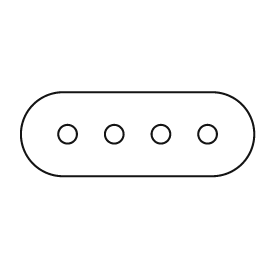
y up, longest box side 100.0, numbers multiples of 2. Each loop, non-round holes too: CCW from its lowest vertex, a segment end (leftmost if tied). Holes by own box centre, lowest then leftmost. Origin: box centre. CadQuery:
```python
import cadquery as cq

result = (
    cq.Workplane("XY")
    .moveTo(-32.0, -18.0)
    .lineTo(32.0, -18.0)
    .threePointArc((50.0, 0.0), (32.0, 18.0))
    .lineTo(-32.0, 18.0)
    .threePointArc((-50.0, 0.0), (-32.0, -18.0))
    .close()
    .moveTo(-30.0, 0.0)
    .circle(4.0)
    .moveTo(-10.0, 0.0)
    .circle(4.0)
    .moveTo(10.0, 0.0)
    .circle(4.0)
    .moveTo(30.0, 0.0)
    .circle(4.0)
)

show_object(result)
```